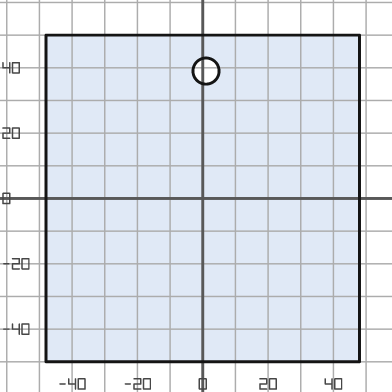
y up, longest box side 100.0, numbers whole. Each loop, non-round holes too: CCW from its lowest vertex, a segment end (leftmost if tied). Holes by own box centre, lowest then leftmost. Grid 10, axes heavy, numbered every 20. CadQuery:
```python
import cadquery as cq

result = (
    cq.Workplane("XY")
    .moveTo(-48.0, -50.0)
    .lineTo(48.0, -50.0)
    .lineTo(48.0, 50.0)
    .lineTo(-48.0, 50.0)
    .close()
    .moveTo(1.0, 39.0)
    .circle(4.0)
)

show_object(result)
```